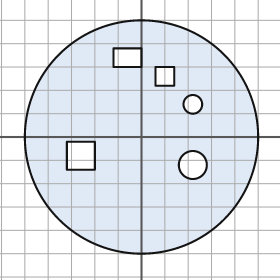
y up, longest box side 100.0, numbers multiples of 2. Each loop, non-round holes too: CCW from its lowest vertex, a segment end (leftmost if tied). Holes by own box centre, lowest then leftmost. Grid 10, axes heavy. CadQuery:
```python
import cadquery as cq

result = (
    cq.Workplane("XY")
    .moveTo(0.0, 0.0)
    .circle(50.0)
    .moveTo(22.0, -12.0)
    .circle(6.0)
    .moveTo(-32.0, -14.0)
    .lineTo(-20.0, -14.0)
    .lineTo(-20.0, -2.0)
    .lineTo(-32.0, -2.0)
    .close()
    .moveTo(22.0, 14.0)
    .circle(4.0)
    .moveTo(6.0, 22.0)
    .lineTo(14.0, 22.0)
    .lineTo(14.0, 30.0)
    .lineTo(6.0, 30.0)
    .close()
    .moveTo(-12.0, 30.0)
    .lineTo(0.0, 30.0)
    .lineTo(0.0, 38.0)
    .lineTo(-12.0, 38.0)
    .close()
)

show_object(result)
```